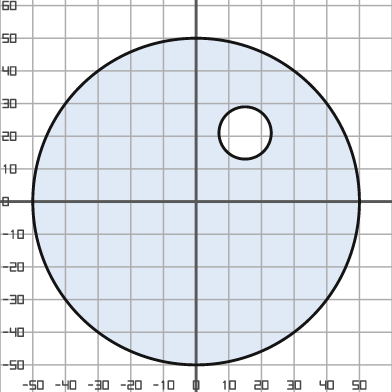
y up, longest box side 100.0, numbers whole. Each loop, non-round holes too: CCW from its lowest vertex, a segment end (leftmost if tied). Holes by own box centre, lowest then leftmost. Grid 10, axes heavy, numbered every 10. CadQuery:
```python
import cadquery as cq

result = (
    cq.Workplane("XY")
    .moveTo(0.0, 0.0)
    .circle(50.0)
    .moveTo(15.0, 21.0)
    .circle(8.0)
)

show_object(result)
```